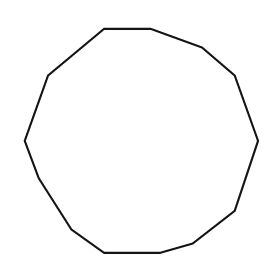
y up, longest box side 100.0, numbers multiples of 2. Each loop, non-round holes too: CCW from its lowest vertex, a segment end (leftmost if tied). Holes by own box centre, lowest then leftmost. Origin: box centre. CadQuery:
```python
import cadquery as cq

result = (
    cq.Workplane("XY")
    .moveTo(-16.0, -48.0)
    .lineTo(8.0, -48.0)
    .lineTo(22.0, -44.0)
    .lineTo(40.0, -30.0)
    .lineTo(50.0, 0.0)
    .lineTo(40.0, 28.0)
    .lineTo(26.0, 40.0)
    .lineTo(4.0, 48.0)
    .lineTo(-16.0, 48.0)
    .lineTo(-40.0, 28.0)
    .lineTo(-50.0, 0.0)
    .lineTo(-44.0, -16.0)
    .lineTo(-30.0, -38.0)
    .close()
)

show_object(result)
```